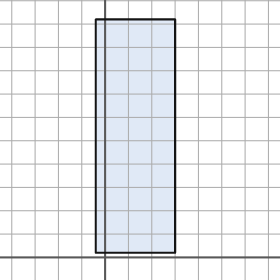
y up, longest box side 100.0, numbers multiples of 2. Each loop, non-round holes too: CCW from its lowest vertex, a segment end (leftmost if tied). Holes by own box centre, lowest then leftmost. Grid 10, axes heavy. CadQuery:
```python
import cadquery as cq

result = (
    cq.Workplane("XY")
    .moveTo(-4.0, 2.0)
    .lineTo(30.0, 2.0)
    .lineTo(30.0, 102.0)
    .lineTo(-4.0, 102.0)
    .close()
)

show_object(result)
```